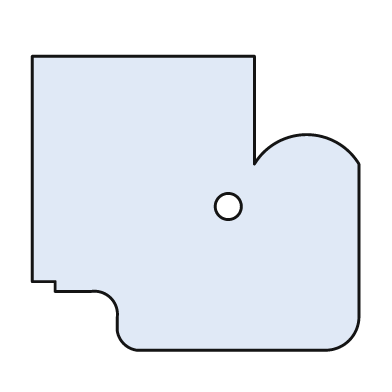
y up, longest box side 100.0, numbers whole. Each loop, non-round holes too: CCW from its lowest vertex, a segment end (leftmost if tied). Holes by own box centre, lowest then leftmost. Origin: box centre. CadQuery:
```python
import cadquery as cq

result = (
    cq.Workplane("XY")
    .moveTo(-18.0, -45.0)
    .lineTo(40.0, -45.0)
    .threePointArc((47.0, -42.0), (50.0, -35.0))
    .lineTo(50.0, 12.0)
    .threePointArc((34.0, 21.0), (18.0, 12.0))
    .lineTo(18.0, 45.0)
    .lineTo(-50.0, 45.0)
    .lineTo(-50.0, -24.0)
    .lineTo(-43.0, -24.0)
    .lineTo(-43.0, -27.0)
    .lineTo(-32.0, -27.0)
    .threePointArc((-26.0, -29.0), (-24.0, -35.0))
    .lineTo(-24.0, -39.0)
    .threePointArc((-22.0, -43.0), (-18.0, -45.0))
    .close()
    .moveTo(10.0, -1.0)
    .circle(4.0)
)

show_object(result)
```